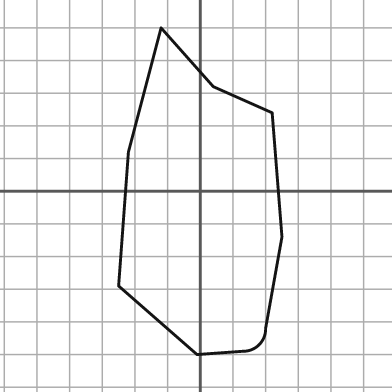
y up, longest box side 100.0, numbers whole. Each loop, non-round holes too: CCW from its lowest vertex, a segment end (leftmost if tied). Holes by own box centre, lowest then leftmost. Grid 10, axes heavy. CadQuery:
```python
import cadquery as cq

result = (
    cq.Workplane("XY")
    .moveTo(-1.0, -50.0)
    .lineTo(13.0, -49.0)
    .threePointArc((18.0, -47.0), (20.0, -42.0))
    .lineTo(25.0, -14.0)
    .lineTo(22.0, 24.0)
    .lineTo(4.0, 32.0)
    .lineTo(-12.0, 50.0)
    .lineTo(-22.0, 12.0)
    .lineTo(-25.0, -29.0)
    .close()
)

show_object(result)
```